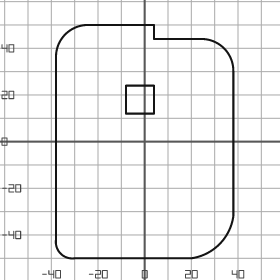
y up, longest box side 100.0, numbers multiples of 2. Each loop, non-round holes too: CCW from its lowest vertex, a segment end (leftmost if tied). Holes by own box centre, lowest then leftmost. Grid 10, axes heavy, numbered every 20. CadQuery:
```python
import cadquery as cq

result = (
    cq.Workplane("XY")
    .moveTo(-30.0, -50.0)
    .lineTo(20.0, -50.0)
    .threePointArc((32.0, -44.0), (38.0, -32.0))
    .lineTo(38.0, 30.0)
    .threePointArc((34.0, 40.0), (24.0, 44.0))
    .lineTo(4.0, 44.0)
    .lineTo(4.0, 50.0)
    .lineTo(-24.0, 50.0)
    .threePointArc((-34.0, 46.0), (-38.0, 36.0))
    .lineTo(-38.0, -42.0)
    .threePointArc((-36.0, -48.0), (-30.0, -50.0))
    .close()
    .moveTo(-8.0, 12.0)
    .lineTo(4.0, 12.0)
    .lineTo(4.0, 24.0)
    .lineTo(-8.0, 24.0)
    .close()
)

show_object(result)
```